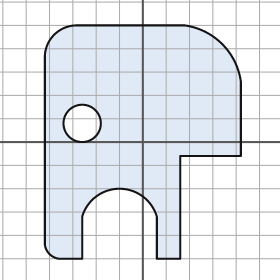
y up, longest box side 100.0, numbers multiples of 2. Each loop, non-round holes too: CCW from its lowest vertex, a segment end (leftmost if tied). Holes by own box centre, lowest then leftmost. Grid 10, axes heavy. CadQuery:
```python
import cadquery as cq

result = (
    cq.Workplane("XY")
    .moveTo(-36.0, -50.0)
    .lineTo(-26.0, -50.0)
    .lineTo(-26.0, -32.0)
    .threePointArc((-10.0, -20.0), (6.0, -32.0))
    .lineTo(6.0, -50.0)
    .lineTo(16.0, -50.0)
    .lineTo(16.0, -6.0)
    .lineTo(42.0, -6.0)
    .lineTo(42.0, 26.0)
    .threePointArc((34.0, 42.0), (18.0, 50.0))
    .lineTo(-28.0, 50.0)
    .threePointArc((-38.0, 46.0), (-42.0, 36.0))
    .lineTo(-42.0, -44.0)
    .threePointArc((-40.0, -48.0), (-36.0, -50.0))
    .close()
    .moveTo(-26.0, 8.0)
    .circle(8.0)
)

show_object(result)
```